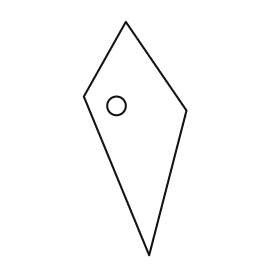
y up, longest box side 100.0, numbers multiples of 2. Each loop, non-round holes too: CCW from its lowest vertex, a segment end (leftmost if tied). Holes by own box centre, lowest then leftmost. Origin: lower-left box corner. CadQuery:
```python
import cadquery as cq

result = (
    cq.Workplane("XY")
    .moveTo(28.0, 0.0)
    .lineTo(44.0, 62.0)
    .lineTo(18.0, 100.0)
    .lineTo(0.0, 68.0)
    .close()
    .moveTo(14.0, 64.0)
    .circle(4.0)
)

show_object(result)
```